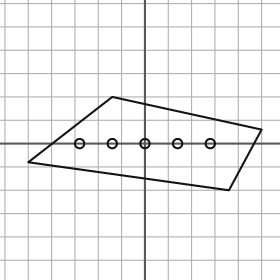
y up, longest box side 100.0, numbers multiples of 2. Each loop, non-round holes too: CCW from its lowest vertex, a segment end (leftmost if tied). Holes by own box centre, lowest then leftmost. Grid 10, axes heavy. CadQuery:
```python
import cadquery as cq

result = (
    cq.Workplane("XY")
    .moveTo(36.0, -20.0)
    .lineTo(50.0, 6.0)
    .lineTo(-14.0, 20.0)
    .lineTo(-50.0, -8.0)
    .close()
    .moveTo(-28.0, 0.0)
    .circle(2.0)
    .moveTo(-14.0, 0.0)
    .circle(2.0)
    .moveTo(0.0, 0.0)
    .circle(2.0)
    .moveTo(14.0, 0.0)
    .circle(2.0)
    .moveTo(28.0, 0.0)
    .circle(2.0)
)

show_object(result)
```